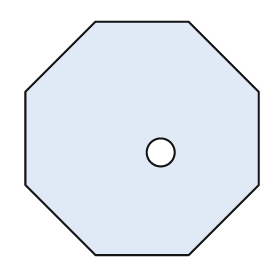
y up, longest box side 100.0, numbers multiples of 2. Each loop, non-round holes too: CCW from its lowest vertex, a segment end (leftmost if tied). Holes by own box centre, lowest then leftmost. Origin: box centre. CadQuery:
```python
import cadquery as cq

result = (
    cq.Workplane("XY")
    .moveTo(-20.0, -50.0)
    .lineTo(20.0, -50.0)
    .lineTo(50.0, -20.0)
    .lineTo(50.0, 20.0)
    .lineTo(20.0, 50.0)
    .lineTo(-20.0, 50.0)
    .lineTo(-50.0, 20.0)
    .lineTo(-50.0, -20.0)
    .close()
    .moveTo(8.0, -6.0)
    .circle(6.0)
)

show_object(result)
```